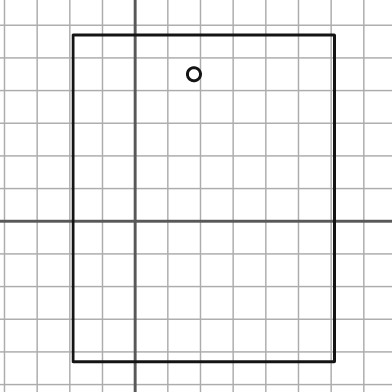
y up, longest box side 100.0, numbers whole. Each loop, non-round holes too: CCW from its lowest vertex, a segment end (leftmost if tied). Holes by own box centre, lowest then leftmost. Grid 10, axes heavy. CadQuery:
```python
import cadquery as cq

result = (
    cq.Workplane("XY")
    .moveTo(-19.0, -43.0)
    .lineTo(61.0, -43.0)
    .lineTo(61.0, 57.0)
    .lineTo(-19.0, 57.0)
    .close()
    .moveTo(18.0, 45.0)
    .circle(2.0)
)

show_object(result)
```